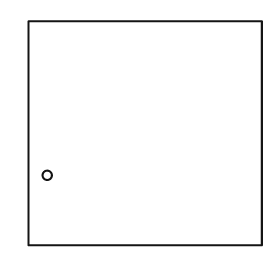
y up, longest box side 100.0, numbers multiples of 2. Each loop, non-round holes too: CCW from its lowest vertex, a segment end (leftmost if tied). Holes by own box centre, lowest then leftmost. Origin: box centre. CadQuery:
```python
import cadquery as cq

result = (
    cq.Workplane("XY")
    .moveTo(-50.0, -48.0)
    .lineTo(50.0, -48.0)
    .lineTo(50.0, 48.0)
    .lineTo(-50.0, 48.0)
    .close()
    .moveTo(-42.0, -18.0)
    .circle(2.0)
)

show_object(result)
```